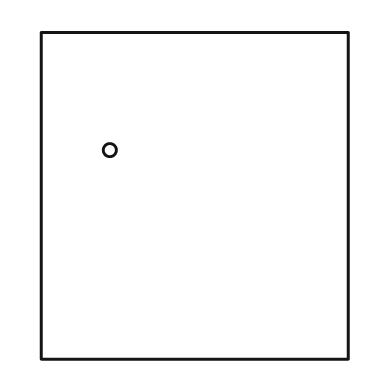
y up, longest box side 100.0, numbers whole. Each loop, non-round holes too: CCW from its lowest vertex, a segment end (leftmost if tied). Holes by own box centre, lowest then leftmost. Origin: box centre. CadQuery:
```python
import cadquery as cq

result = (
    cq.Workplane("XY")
    .moveTo(-47.0, -50.0)
    .lineTo(47.0, -50.0)
    .lineTo(47.0, 50.0)
    .lineTo(-47.0, 50.0)
    .close()
    .moveTo(-26.0, 14.0)
    .circle(2.0)
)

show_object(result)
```